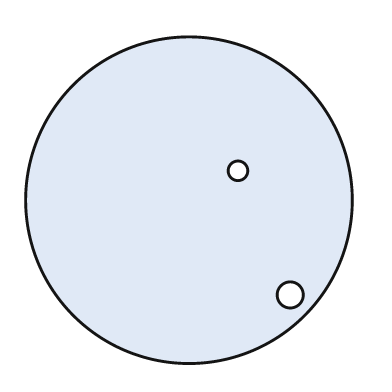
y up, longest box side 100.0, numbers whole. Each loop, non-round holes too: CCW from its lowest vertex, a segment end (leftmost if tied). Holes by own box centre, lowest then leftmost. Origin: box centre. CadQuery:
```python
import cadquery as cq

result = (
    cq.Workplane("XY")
    .moveTo(0.0, 0.0)
    .circle(50.0)
    .moveTo(31.0, -29.0)
    .circle(4.0)
    .moveTo(15.0, 9.0)
    .circle(3.0)
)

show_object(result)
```